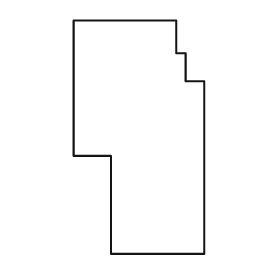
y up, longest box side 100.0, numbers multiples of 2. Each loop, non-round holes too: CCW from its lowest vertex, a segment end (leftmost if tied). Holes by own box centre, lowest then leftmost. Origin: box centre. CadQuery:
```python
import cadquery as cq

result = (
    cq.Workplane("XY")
    .moveTo(-12.0, -50.0)
    .lineTo(28.0, -50.0)
    .lineTo(28.0, 24.0)
    .lineTo(20.0, 24.0)
    .lineTo(20.0, 36.0)
    .lineTo(16.0, 36.0)
    .lineTo(16.0, 50.0)
    .lineTo(-28.0, 50.0)
    .lineTo(-28.0, -8.0)
    .lineTo(-12.0, -8.0)
    .close()
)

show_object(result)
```